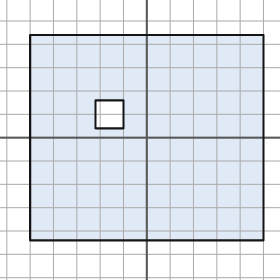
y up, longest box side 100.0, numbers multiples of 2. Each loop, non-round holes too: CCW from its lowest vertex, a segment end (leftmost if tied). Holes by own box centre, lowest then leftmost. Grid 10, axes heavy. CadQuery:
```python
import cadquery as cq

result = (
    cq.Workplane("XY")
    .moveTo(-50.0, -44.0)
    .lineTo(50.0, -44.0)
    .lineTo(50.0, 44.0)
    .lineTo(-50.0, 44.0)
    .close()
    .moveTo(-22.0, 4.0)
    .lineTo(-10.0, 4.0)
    .lineTo(-10.0, 16.0)
    .lineTo(-22.0, 16.0)
    .close()
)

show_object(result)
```